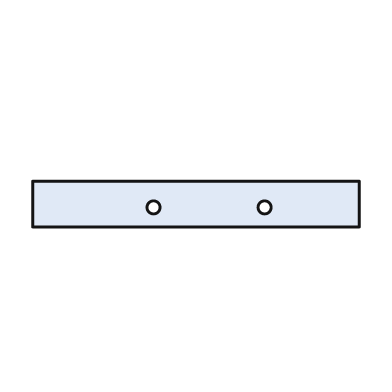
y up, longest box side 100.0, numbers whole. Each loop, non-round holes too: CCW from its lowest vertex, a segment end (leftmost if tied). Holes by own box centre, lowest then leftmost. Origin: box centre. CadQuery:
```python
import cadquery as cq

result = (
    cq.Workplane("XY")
    .moveTo(-50.0, -7.0)
    .lineTo(50.0, -7.0)
    .lineTo(50.0, 7.0)
    .lineTo(-50.0, 7.0)
    .close()
    .moveTo(-13.0, -1.0)
    .circle(2.0)
    .moveTo(21.0, -1.0)
    .circle(2.0)
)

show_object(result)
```